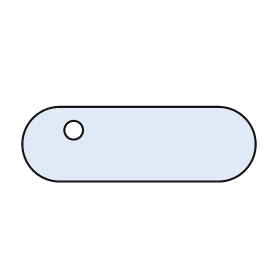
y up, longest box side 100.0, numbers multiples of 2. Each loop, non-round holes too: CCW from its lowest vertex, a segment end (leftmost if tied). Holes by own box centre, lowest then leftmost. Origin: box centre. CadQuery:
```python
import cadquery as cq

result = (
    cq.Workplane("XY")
    .moveTo(-34.0, -16.0)
    .lineTo(34.0, -16.0)
    .threePointArc((50.0, 0.0), (34.0, 16.0))
    .lineTo(-34.0, 16.0)
    .threePointArc((-50.0, 0.0), (-34.0, -16.0))
    .close()
    .moveTo(-28.0, 6.0)
    .circle(4.0)
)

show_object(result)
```